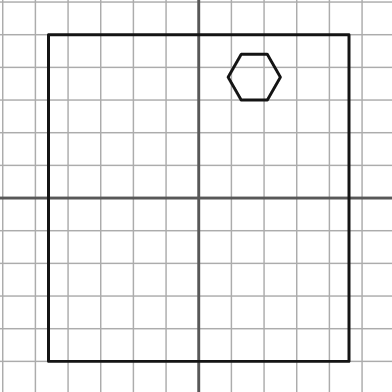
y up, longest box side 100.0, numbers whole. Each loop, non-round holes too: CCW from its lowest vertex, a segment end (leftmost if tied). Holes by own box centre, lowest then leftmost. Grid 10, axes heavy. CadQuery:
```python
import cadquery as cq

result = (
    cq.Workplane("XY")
    .moveTo(-46.0, -50.0)
    .lineTo(46.0, -50.0)
    .lineTo(46.0, 50.0)
    .lineTo(-46.0, 50.0)
    .close()
    .moveTo(13.0, 30.0)
    .lineTo(21.0, 30.0)
    .lineTo(25.0, 37.0)
    .lineTo(21.0, 44.0)
    .lineTo(13.0, 44.0)
    .lineTo(9.0, 37.0)
    .close()
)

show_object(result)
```